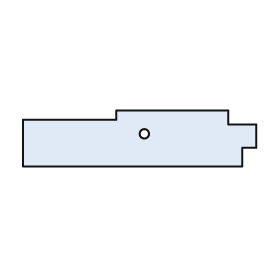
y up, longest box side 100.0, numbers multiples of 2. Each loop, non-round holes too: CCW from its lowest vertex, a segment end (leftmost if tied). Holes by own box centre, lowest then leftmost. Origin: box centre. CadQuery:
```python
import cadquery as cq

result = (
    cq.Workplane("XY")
    .moveTo(-50.0, -12.0)
    .lineTo(44.0, -12.0)
    .lineTo(44.0, -4.0)
    .lineTo(50.0, -4.0)
    .lineTo(50.0, 6.0)
    .lineTo(38.0, 6.0)
    .lineTo(38.0, 12.0)
    .lineTo(-10.0, 12.0)
    .lineTo(-10.0, 8.0)
    .lineTo(-50.0, 8.0)
    .close()
    .moveTo(2.0, 2.0)
    .circle(2.0)
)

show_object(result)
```